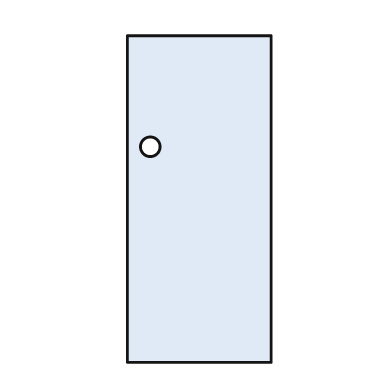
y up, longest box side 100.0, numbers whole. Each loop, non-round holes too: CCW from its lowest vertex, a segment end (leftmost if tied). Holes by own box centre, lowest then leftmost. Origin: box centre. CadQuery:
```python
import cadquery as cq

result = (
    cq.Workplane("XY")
    .moveTo(-22.0, -50.0)
    .lineTo(22.0, -50.0)
    .lineTo(22.0, 50.0)
    .lineTo(-22.0, 50.0)
    .close()
    .moveTo(-15.0, 16.0)
    .circle(3.0)
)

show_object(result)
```